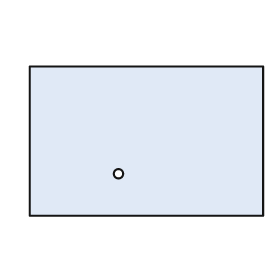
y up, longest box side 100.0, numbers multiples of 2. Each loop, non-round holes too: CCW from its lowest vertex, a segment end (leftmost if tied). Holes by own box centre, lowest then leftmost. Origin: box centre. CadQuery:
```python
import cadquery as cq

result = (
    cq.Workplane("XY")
    .moveTo(-50.0, -32.0)
    .lineTo(50.0, -32.0)
    .lineTo(50.0, 32.0)
    .lineTo(-50.0, 32.0)
    .close()
    .moveTo(-12.0, -14.0)
    .circle(2.0)
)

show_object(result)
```